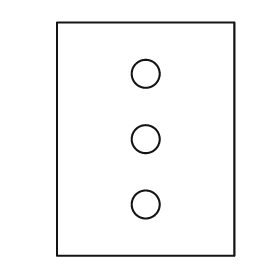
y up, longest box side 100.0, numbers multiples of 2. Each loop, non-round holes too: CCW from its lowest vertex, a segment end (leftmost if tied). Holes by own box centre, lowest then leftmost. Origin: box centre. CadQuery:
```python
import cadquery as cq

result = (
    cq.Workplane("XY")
    .moveTo(-38.0, -50.0)
    .lineTo(38.0, -50.0)
    .lineTo(38.0, 50.0)
    .lineTo(-38.0, 50.0)
    .close()
    .moveTo(0.0, -28.0)
    .circle(6.0)
    .moveTo(0.0, 0.0)
    .circle(6.0)
    .moveTo(0.0, 28.0)
    .circle(6.0)
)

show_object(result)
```